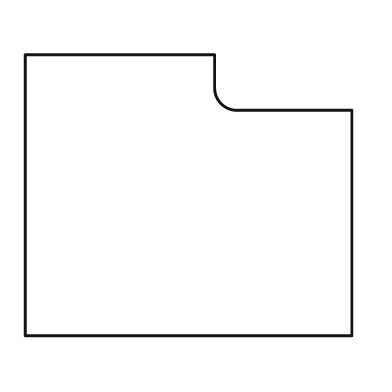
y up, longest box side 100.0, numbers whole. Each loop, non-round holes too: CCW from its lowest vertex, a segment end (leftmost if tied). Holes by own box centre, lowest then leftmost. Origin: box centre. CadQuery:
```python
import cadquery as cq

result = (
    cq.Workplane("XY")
    .moveTo(-50.0, -43.0)
    .lineTo(50.0, -43.0)
    .lineTo(50.0, 26.0)
    .lineTo(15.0, 26.0)
    .threePointArc((10.0, 28.0), (8.0, 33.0))
    .lineTo(8.0, 43.0)
    .lineTo(-50.0, 43.0)
    .close()
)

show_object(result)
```